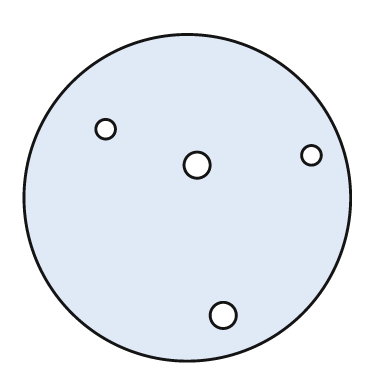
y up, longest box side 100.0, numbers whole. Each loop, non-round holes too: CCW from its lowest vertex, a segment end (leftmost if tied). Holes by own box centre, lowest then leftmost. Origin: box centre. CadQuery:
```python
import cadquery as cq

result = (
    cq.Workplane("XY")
    .moveTo(0.0, 0.0)
    .circle(50.0)
    .moveTo(11.0, -36.0)
    .circle(4.0)
    .moveTo(3.0, 10.0)
    .circle(4.0)
    .moveTo(38.0, 13.0)
    .circle(3.0)
    .moveTo(-25.0, 21.0)
    .circle(3.0)
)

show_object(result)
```